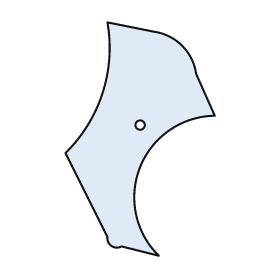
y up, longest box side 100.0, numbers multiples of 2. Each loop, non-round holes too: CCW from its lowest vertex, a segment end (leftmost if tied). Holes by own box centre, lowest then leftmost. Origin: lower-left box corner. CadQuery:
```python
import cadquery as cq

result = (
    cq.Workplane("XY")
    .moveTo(40.0, 0.0)
    .threePointArc((32.0, 38.0), (64.0, 60.0))
    .lineTo(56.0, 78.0)
    .threePointArc((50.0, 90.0), (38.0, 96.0))
    .lineTo(18.0, 100.0)
    .threePointArc((16.0, 70.0), (0.0, 44.0))
    .lineTo(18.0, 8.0)
    .threePointArc((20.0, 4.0), (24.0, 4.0))
    .close()
    .moveTo(32.0, 56.0)
    .circle(2.0)
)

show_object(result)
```